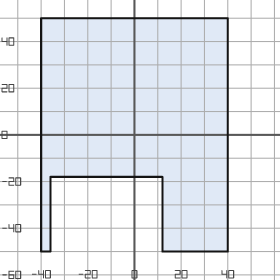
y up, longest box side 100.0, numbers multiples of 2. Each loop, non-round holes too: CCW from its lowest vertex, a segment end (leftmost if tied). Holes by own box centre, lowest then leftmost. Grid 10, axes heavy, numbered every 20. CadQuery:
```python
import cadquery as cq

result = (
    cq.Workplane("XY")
    .moveTo(-40.0, -50.0)
    .lineTo(-36.0, -50.0)
    .lineTo(-36.0, -18.0)
    .lineTo(12.0, -18.0)
    .lineTo(12.0, -50.0)
    .lineTo(40.0, -50.0)
    .lineTo(40.0, 50.0)
    .lineTo(-40.0, 50.0)
    .close()
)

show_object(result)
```